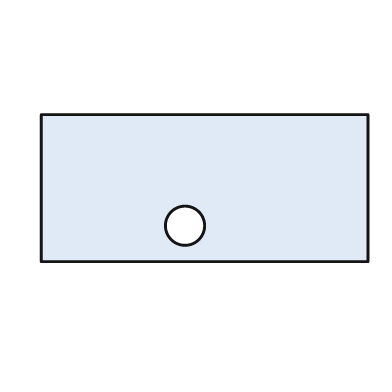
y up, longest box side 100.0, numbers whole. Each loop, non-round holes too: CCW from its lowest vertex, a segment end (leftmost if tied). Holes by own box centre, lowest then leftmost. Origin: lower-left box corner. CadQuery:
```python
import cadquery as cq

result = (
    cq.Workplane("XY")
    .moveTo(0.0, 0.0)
    .lineTo(100.0, 0.0)
    .lineTo(100.0, 45.0)
    .lineTo(0.0, 45.0)
    .close()
    .moveTo(44.0, 11.0)
    .circle(6.0)
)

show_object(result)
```